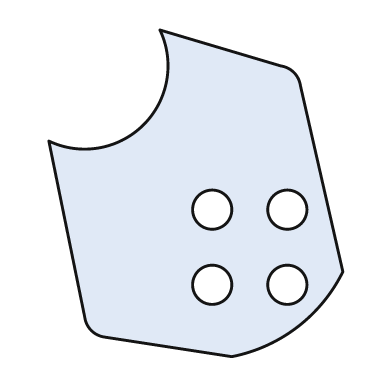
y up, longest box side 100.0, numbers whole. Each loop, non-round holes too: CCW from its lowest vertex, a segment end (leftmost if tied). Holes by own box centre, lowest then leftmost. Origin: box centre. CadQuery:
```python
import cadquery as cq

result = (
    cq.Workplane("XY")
    .moveTo(11.0, -50.0)
    .threePointArc((31.0, -41.0), (45.0, -24.0))
    .lineTo(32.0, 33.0)
    .threePointArc((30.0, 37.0), (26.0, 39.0))
    .lineTo(-11.0, 50.0)
    .threePointArc((-16.0, 21.0), (-45.0, 16.0))
    .lineTo(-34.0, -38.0)
    .threePointArc((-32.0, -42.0), (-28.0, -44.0))
    .close()
    .moveTo(5.0, -28.0)
    .circle(6.0)
    .moveTo(28.0, -28.0)
    .circle(6.0)
    .moveTo(5.0, -5.0)
    .circle(6.0)
    .moveTo(28.0, -5.0)
    .circle(6.0)
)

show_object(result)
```